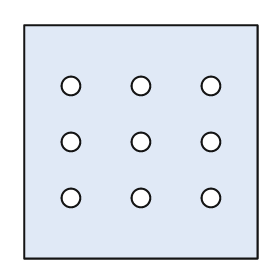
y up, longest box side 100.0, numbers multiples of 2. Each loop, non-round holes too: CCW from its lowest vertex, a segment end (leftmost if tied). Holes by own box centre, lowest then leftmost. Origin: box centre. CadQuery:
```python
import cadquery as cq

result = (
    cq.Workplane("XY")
    .moveTo(-50.0, -50.0)
    .lineTo(50.0, -50.0)
    .lineTo(50.0, 50.0)
    .lineTo(-50.0, 50.0)
    .close()
    .moveTo(-30.0, -24.0)
    .circle(4.0)
    .moveTo(0.0, -24.0)
    .circle(4.0)
    .moveTo(30.0, -24.0)
    .circle(4.0)
    .moveTo(-30.0, 0.0)
    .circle(4.0)
    .moveTo(0.0, 0.0)
    .circle(4.0)
    .moveTo(30.0, 0.0)
    .circle(4.0)
    .moveTo(-30.0, 24.0)
    .circle(4.0)
    .moveTo(0.0, 24.0)
    .circle(4.0)
    .moveTo(30.0, 24.0)
    .circle(4.0)
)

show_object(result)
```